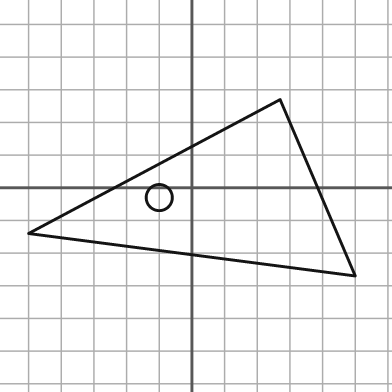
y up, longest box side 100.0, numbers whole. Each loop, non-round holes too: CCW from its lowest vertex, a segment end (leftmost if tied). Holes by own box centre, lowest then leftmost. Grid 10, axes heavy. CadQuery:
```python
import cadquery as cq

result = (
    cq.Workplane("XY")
    .moveTo(50.0, -27.0)
    .lineTo(27.0, 27.0)
    .lineTo(-50.0, -14.0)
    .close()
    .moveTo(-10.0, -3.0)
    .circle(4.0)
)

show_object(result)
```